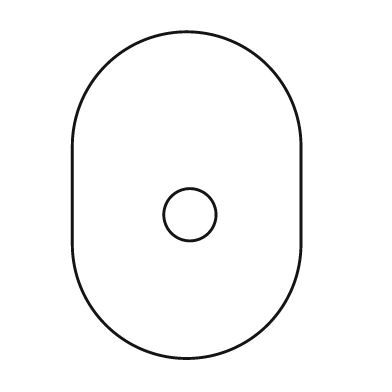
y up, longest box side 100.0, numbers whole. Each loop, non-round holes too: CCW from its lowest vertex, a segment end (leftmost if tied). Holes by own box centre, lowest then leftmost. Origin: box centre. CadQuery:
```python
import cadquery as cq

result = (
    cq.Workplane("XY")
    .moveTo(-35.0, -15.0)
    .threePointArc((0.0, -50.0), (35.0, -15.0))
    .lineTo(35.0, 15.0)
    .threePointArc((0.0, 50.0), (-35.0, 15.0))
    .close()
    .moveTo(1.0, -6.0)
    .circle(8.0)
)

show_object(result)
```